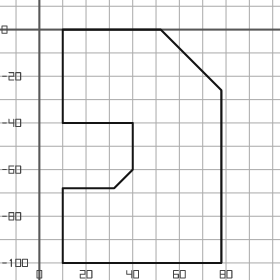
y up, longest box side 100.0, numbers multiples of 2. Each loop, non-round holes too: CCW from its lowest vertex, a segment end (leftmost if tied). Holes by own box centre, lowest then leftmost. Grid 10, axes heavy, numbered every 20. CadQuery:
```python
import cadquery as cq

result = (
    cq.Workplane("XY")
    .moveTo(10.0, -100.0)
    .lineTo(78.0, -100.0)
    .lineTo(78.0, -26.0)
    .lineTo(52.0, 0.0)
    .lineTo(10.0, 0.0)
    .lineTo(10.0, -40.0)
    .lineTo(40.0, -40.0)
    .lineTo(40.0, -60.0)
    .lineTo(32.0, -68.0)
    .lineTo(10.0, -68.0)
    .close()
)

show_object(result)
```